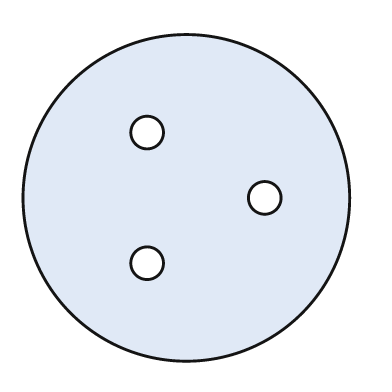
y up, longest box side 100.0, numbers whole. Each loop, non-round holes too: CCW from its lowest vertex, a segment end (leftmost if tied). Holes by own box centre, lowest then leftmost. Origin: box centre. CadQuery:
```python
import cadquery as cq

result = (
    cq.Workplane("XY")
    .moveTo(0.0, 0.0)
    .circle(50.0)
    .moveTo(-12.0, -20.0)
    .circle(5.0)
    .moveTo(24.0, 0.0)
    .circle(5.0)
    .moveTo(-12.0, 20.0)
    .circle(5.0)
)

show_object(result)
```